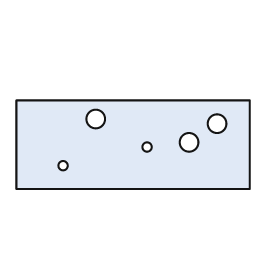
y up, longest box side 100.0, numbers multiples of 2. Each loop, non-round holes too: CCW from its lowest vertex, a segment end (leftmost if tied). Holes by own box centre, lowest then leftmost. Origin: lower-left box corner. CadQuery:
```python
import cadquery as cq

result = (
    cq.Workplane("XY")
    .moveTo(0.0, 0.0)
    .lineTo(100.0, 0.0)
    .lineTo(100.0, 38.0)
    .lineTo(0.0, 38.0)
    .close()
    .moveTo(20.0, 10.0)
    .circle(2.0)
    .moveTo(56.0, 18.0)
    .circle(2.0)
    .moveTo(74.0, 20.0)
    .circle(4.0)
    .moveTo(86.0, 28.0)
    .circle(4.0)
    .moveTo(34.0, 30.0)
    .circle(4.0)
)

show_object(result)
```